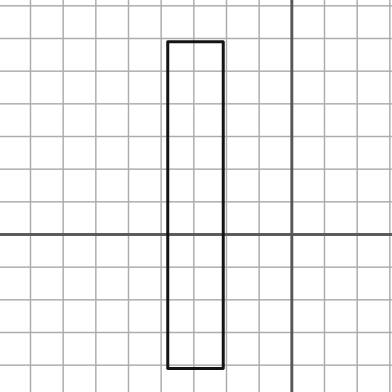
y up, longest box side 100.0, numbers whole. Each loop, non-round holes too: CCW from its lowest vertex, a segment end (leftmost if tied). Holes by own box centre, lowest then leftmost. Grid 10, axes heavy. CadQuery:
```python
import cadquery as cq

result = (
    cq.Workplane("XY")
    .moveTo(-38.0, -41.0)
    .lineTo(-21.0, -41.0)
    .lineTo(-21.0, 59.0)
    .lineTo(-38.0, 59.0)
    .close()
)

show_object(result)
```